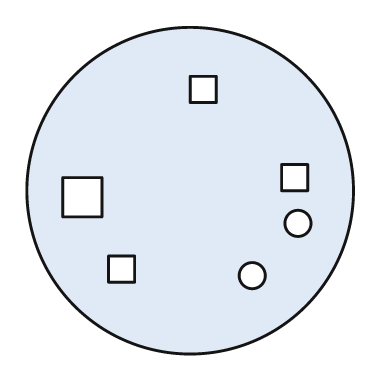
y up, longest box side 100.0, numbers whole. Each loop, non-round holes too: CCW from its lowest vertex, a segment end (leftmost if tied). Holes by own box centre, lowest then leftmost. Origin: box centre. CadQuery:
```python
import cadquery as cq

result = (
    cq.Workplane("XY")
    .moveTo(0.0, 0.0)
    .circle(50.0)
    .moveTo(19.0, -26.0)
    .circle(4.0)
    .moveTo(-25.0, -28.0)
    .lineTo(-17.0, -28.0)
    .lineTo(-17.0, -20.0)
    .lineTo(-25.0, -20.0)
    .close()
    .moveTo(33.0, -10.0)
    .circle(4.0)
    .moveTo(-39.0, -8.0)
    .lineTo(-27.0, -8.0)
    .lineTo(-27.0, 4.0)
    .lineTo(-39.0, 4.0)
    .close()
    .moveTo(28.0, 0.0)
    .lineTo(36.0, 0.0)
    .lineTo(36.0, 8.0)
    .lineTo(28.0, 8.0)
    .close()
    .moveTo(0.0, 27.0)
    .lineTo(8.0, 27.0)
    .lineTo(8.0, 35.0)
    .lineTo(0.0, 35.0)
    .close()
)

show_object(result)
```